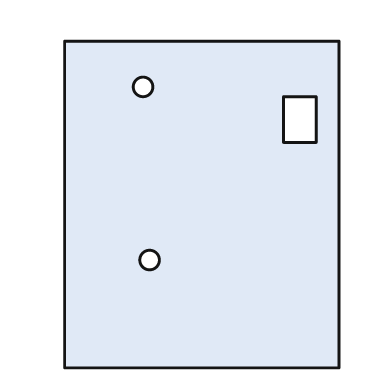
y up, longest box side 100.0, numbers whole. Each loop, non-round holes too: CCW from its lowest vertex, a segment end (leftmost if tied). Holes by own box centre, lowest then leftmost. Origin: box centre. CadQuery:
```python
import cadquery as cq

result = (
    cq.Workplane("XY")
    .moveTo(-42.0, -50.0)
    .lineTo(42.0, -50.0)
    .lineTo(42.0, 50.0)
    .lineTo(-42.0, 50.0)
    .close()
    .moveTo(-16.0, -17.0)
    .circle(3.0)
    .moveTo(25.0, 19.0)
    .lineTo(35.0, 19.0)
    .lineTo(35.0, 33.0)
    .lineTo(25.0, 33.0)
    .close()
    .moveTo(-18.0, 36.0)
    .circle(3.0)
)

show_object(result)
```